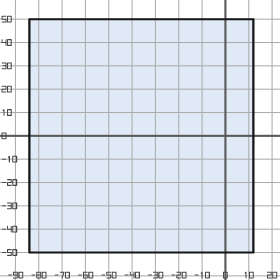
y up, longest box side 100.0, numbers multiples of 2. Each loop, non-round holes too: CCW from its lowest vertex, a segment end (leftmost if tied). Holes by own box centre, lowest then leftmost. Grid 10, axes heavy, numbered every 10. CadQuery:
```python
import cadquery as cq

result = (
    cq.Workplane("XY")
    .moveTo(-84.0, -50.0)
    .lineTo(12.0, -50.0)
    .lineTo(12.0, 50.0)
    .lineTo(-84.0, 50.0)
    .close()
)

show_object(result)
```